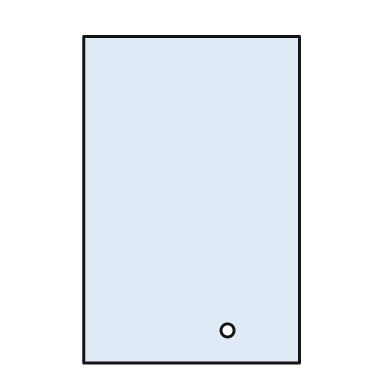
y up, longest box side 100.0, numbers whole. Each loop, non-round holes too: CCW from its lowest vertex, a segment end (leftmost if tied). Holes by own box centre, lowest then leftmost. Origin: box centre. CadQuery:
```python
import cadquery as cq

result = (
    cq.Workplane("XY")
    .moveTo(-33.0, -50.0)
    .lineTo(33.0, -50.0)
    .lineTo(33.0, 50.0)
    .lineTo(-33.0, 50.0)
    .close()
    .moveTo(11.0, -40.0)
    .circle(2.0)
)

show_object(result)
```